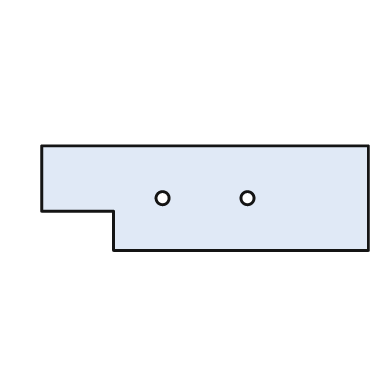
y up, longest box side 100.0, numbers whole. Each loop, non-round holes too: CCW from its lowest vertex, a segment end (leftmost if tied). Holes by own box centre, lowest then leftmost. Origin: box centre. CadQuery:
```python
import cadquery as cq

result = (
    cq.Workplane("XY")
    .moveTo(-28.0, -16.0)
    .lineTo(50.0, -16.0)
    .lineTo(50.0, 16.0)
    .lineTo(-50.0, 16.0)
    .lineTo(-50.0, -4.0)
    .lineTo(-28.0, -4.0)
    .close()
    .moveTo(-13.0, 0.0)
    .circle(2.0)
    .moveTo(13.0, 0.0)
    .circle(2.0)
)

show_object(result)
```